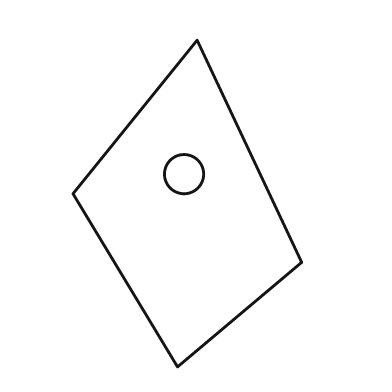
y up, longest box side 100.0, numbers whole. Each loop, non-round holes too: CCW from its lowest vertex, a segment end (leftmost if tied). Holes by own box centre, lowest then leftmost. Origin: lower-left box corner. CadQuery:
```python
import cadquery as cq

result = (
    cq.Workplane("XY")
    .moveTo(32.0, 0.0)
    .lineTo(70.0, 32.0)
    .lineTo(38.0, 100.0)
    .lineTo(0.0, 53.0)
    .close()
    .moveTo(34.0, 59.0)
    .circle(6.0)
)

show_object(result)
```